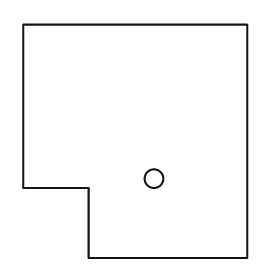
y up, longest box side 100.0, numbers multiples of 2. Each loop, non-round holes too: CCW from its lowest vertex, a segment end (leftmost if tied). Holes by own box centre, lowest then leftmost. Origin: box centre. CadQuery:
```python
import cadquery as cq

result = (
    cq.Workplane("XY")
    .moveTo(-20.0, -50.0)
    .lineTo(48.0, -50.0)
    .lineTo(48.0, 50.0)
    .lineTo(-48.0, 50.0)
    .lineTo(-48.0, -20.0)
    .lineTo(-20.0, -20.0)
    .close()
    .moveTo(8.0, -16.0)
    .circle(4.0)
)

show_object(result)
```